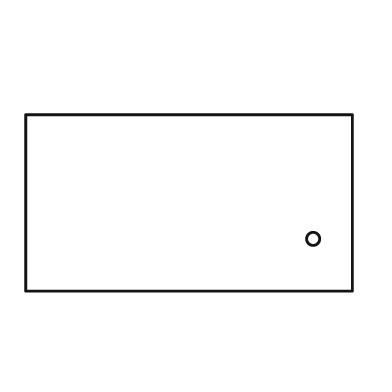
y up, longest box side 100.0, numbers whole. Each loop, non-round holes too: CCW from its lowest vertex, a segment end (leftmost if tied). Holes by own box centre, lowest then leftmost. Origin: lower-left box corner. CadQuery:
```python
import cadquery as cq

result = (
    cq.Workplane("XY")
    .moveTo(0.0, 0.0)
    .lineTo(100.0, 0.0)
    .lineTo(100.0, 54.0)
    .lineTo(0.0, 54.0)
    .close()
    .moveTo(88.0, 16.0)
    .circle(2.0)
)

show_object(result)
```